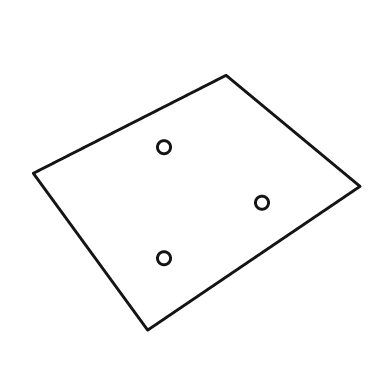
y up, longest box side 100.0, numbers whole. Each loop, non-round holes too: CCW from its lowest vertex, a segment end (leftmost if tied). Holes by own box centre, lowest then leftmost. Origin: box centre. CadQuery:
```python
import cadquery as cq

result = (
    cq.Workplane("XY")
    .moveTo(-15.0, -39.0)
    .lineTo(50.0, 5.0)
    .lineTo(9.0, 39.0)
    .lineTo(-50.0, 9.0)
    .close()
    .moveTo(-10.0, -17.0)
    .circle(2.0)
    .moveTo(20.0, 0.0)
    .circle(2.0)
    .moveTo(-10.0, 17.0)
    .circle(2.0)
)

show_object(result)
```